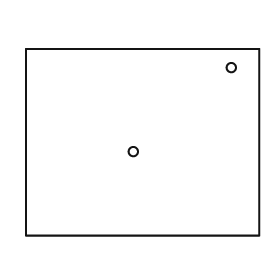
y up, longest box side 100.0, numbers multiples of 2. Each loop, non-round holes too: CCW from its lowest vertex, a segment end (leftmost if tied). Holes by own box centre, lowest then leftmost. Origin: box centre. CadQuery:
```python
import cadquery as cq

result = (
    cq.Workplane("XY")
    .moveTo(-50.0, -40.0)
    .lineTo(50.0, -40.0)
    .lineTo(50.0, 40.0)
    .lineTo(-50.0, 40.0)
    .close()
    .moveTo(-4.0, -4.0)
    .circle(2.0)
    .moveTo(38.0, 32.0)
    .circle(2.0)
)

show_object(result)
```